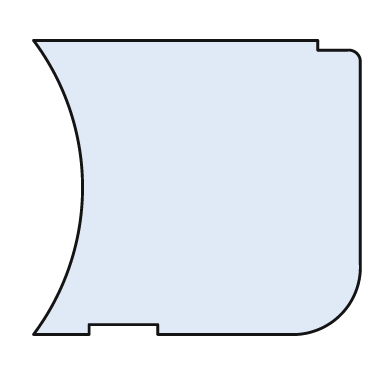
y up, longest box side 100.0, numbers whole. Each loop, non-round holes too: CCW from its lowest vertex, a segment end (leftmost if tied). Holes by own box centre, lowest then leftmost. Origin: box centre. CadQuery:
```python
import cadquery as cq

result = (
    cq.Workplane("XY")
    .moveTo(-50.0, -45.0)
    .lineTo(-33.0, -45.0)
    .lineTo(-33.0, -42.0)
    .lineTo(-12.0, -42.0)
    .lineTo(-12.0, -45.0)
    .lineTo(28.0, -45.0)
    .threePointArc((44.0, -39.0), (50.0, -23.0))
    .lineTo(50.0, 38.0)
    .threePointArc((49.0, 41.0), (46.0, 42.0))
    .lineTo(37.0, 42.0)
    .lineTo(37.0, 45.0)
    .lineTo(-50.0, 45.0)
    .threePointArc((-35.0, 0.0), (-50.0, -45.0))
    .close()
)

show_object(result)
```